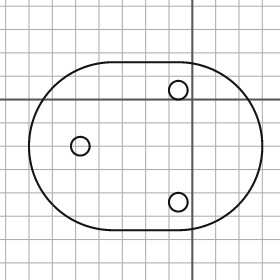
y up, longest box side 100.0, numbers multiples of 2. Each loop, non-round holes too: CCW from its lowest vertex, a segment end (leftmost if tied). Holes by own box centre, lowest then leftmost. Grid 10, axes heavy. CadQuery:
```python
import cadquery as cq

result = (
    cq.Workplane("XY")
    .moveTo(-34.0, -56.0)
    .lineTo(-6.0, -56.0)
    .threePointArc((30.0, -20.0), (-6.0, 16.0))
    .lineTo(-34.0, 16.0)
    .threePointArc((-70.0, -20.0), (-34.0, -56.0))
    .close()
    .moveTo(-6.0, -44.0)
    .circle(4.0)
    .moveTo(-48.0, -20.0)
    .circle(4.0)
    .moveTo(-6.0, 4.0)
    .circle(4.0)
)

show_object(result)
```